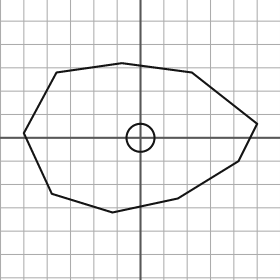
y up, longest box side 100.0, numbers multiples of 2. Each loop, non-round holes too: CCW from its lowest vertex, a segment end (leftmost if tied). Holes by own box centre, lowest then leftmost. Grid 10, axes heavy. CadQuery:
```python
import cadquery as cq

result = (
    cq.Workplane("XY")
    .moveTo(-12.0, -32.0)
    .lineTo(16.0, -26.0)
    .lineTo(42.0, -10.0)
    .lineTo(50.0, 6.0)
    .lineTo(22.0, 28.0)
    .lineTo(-8.0, 32.0)
    .lineTo(-36.0, 28.0)
    .lineTo(-50.0, 2.0)
    .lineTo(-38.0, -24.0)
    .close()
    .moveTo(0.0, 0.0)
    .circle(6.0)
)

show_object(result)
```